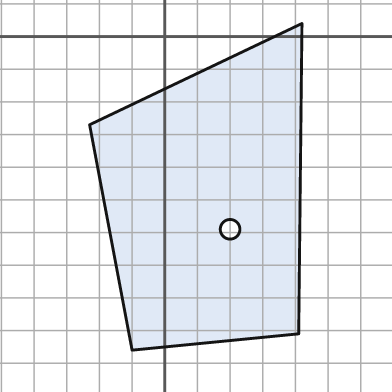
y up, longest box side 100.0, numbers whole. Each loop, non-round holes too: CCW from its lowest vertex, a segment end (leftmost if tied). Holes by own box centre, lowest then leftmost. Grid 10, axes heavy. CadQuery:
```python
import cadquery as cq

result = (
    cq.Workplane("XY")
    .moveTo(-10.0, -96.0)
    .lineTo(41.0, -91.0)
    .lineTo(42.0, 4.0)
    .lineTo(-23.0, -27.0)
    .close()
    .moveTo(20.0, -59.0)
    .circle(3.0)
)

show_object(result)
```